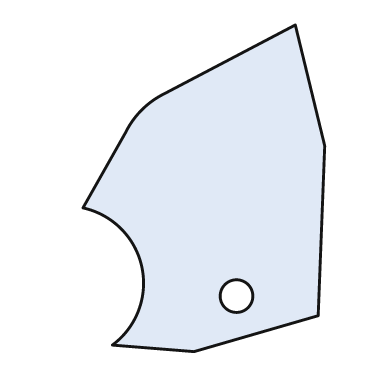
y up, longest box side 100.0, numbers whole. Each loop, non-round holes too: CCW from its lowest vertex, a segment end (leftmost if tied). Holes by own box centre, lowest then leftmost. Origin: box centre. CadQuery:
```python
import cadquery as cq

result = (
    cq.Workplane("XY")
    .moveTo(-3.0, -50.0)
    .lineTo(35.0, -39.0)
    .lineTo(37.0, 13.0)
    .lineTo(28.0, 50.0)
    .lineTo(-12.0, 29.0)
    .threePointArc((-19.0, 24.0), (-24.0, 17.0))
    .lineTo(-37.0, -6.0)
    .threePointArc((-19.0, -24.0), (-28.0, -48.0))
    .close()
    .moveTo(10.0, -33.0)
    .circle(5.0)
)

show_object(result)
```